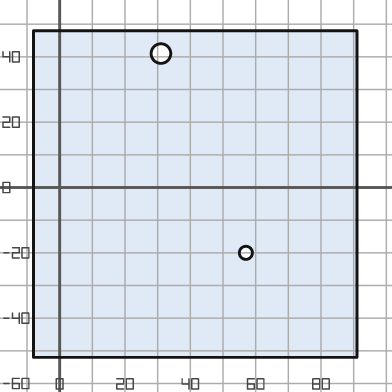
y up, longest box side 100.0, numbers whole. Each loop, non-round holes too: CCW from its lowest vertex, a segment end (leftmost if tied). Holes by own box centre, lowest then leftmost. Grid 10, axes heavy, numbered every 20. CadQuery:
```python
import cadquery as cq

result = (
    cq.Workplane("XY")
    .moveTo(-8.0, -52.0)
    .lineTo(91.0, -52.0)
    .lineTo(91.0, 48.0)
    .lineTo(-8.0, 48.0)
    .close()
    .moveTo(57.0, -20.0)
    .circle(2.0)
    .moveTo(31.0, 41.0)
    .circle(3.0)
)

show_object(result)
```